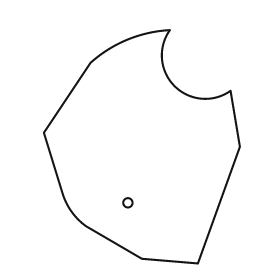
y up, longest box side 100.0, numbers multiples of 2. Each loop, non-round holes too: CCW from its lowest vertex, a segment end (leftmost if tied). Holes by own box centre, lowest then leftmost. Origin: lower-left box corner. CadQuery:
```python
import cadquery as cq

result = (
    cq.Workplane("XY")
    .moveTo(66.0, 0.0)
    .lineTo(84.0, 50.0)
    .lineTo(80.0, 74.0)
    .threePointArc((56.0, 76.0), (54.0, 100.0))
    .threePointArc((36.0, 96.0), (20.0, 86.0))
    .lineTo(0.0, 56.0)
    .lineTo(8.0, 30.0)
    .threePointArc((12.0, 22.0), (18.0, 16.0))
    .lineTo(42.0, 2.0)
    .close()
    .moveTo(36.0, 26.0)
    .circle(2.0)
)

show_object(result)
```